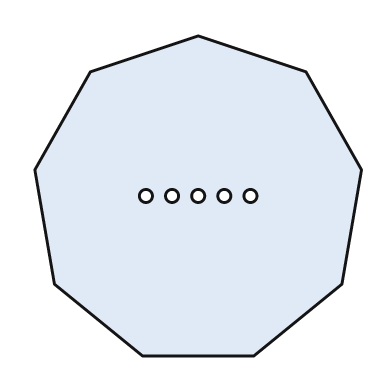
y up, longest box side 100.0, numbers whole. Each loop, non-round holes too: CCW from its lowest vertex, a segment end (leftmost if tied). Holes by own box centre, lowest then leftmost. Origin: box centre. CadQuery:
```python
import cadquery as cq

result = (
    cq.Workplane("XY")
    .moveTo(-17.0, -49.0)
    .lineTo(17.0, -49.0)
    .lineTo(44.0, -27.0)
    .lineTo(50.0, 8.0)
    .lineTo(33.0, 38.0)
    .lineTo(0.0, 49.0)
    .lineTo(-33.0, 38.0)
    .lineTo(-50.0, 8.0)
    .lineTo(-44.0, -27.0)
    .close()
    .moveTo(-16.0, 0.0)
    .circle(2.0)
    .moveTo(-8.0, 0.0)
    .circle(2.0)
    .moveTo(0.0, 0.0)
    .circle(2.0)
    .moveTo(8.0, 0.0)
    .circle(2.0)
    .moveTo(16.0, 0.0)
    .circle(2.0)
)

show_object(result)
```